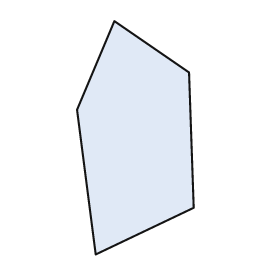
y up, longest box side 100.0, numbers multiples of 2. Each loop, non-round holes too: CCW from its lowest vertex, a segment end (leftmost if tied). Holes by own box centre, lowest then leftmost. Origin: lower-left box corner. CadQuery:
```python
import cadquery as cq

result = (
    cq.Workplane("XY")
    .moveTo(8.0, 0.0)
    .lineTo(50.0, 20.0)
    .lineTo(48.0, 78.0)
    .lineTo(16.0, 100.0)
    .lineTo(0.0, 62.0)
    .close()
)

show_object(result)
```